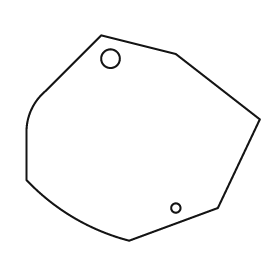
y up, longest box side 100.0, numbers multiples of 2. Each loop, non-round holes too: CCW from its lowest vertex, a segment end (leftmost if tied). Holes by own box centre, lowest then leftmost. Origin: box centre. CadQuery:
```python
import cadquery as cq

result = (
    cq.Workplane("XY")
    .moveTo(-6.0, -44.0)
    .lineTo(32.0, -30.0)
    .lineTo(50.0, 8.0)
    .lineTo(14.0, 36.0)
    .lineTo(-18.0, 44.0)
    .lineTo(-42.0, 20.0)
    .threePointArc((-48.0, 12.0), (-50.0, 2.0))
    .lineTo(-50.0, -18.0)
    .threePointArc((-30.0, -34.0), (-6.0, -44.0))
    .close()
    .moveTo(14.0, -30.0)
    .circle(2.0)
    .moveTo(-14.0, 34.0)
    .circle(4.0)
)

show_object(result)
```